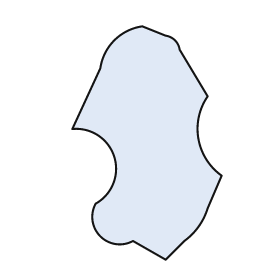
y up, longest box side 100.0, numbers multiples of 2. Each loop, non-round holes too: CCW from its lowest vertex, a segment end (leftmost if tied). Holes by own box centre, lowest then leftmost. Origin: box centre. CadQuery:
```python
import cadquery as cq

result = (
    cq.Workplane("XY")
    .moveTo(8.0, -50.0)
    .lineTo(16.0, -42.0)
    .threePointArc((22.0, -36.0), (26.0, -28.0))
    .lineTo(32.0, -14.0)
    .threePointArc((22.0, 2.0), (26.0, 20.0))
    .lineTo(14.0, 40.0)
    .threePointArc((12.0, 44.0), (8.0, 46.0))
    .lineTo(-2.0, 50.0)
    .threePointArc((-14.0, 44.0), (-20.0, 32.0))
    .lineTo(-32.0, 6.0)
    .threePointArc((-14.0, -6.0), (-22.0, -26.0))
    .threePointArc((-20.0, -40.0), (-6.0, -42.0))
    .close()
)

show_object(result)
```